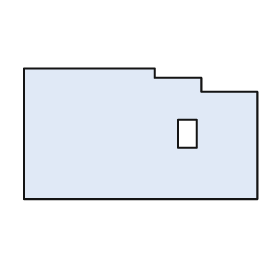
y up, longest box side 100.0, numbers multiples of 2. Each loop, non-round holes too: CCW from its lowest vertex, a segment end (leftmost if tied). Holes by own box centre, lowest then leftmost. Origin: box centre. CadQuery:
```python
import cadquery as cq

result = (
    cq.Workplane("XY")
    .moveTo(-50.0, -28.0)
    .lineTo(50.0, -28.0)
    .lineTo(50.0, 18.0)
    .lineTo(26.0, 18.0)
    .lineTo(26.0, 24.0)
    .lineTo(6.0, 24.0)
    .lineTo(6.0, 28.0)
    .lineTo(-50.0, 28.0)
    .close()
    .moveTo(16.0, -6.0)
    .lineTo(24.0, -6.0)
    .lineTo(24.0, 6.0)
    .lineTo(16.0, 6.0)
    .close()
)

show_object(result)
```